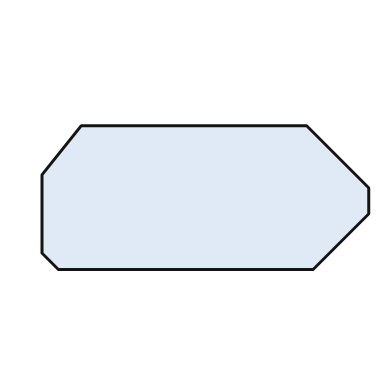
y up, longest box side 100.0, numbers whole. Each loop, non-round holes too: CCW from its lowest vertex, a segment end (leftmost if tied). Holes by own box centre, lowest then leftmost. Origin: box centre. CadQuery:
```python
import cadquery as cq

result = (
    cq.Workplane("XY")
    .moveTo(-45.0, -22.0)
    .lineTo(33.0, -22.0)
    .lineTo(50.0, -5.0)
    .lineTo(50.0, 3.0)
    .lineTo(31.0, 22.0)
    .lineTo(-38.0, 22.0)
    .lineTo(-50.0, 7.0)
    .lineTo(-50.0, -17.0)
    .close()
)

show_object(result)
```